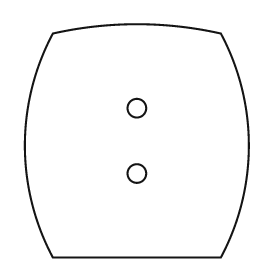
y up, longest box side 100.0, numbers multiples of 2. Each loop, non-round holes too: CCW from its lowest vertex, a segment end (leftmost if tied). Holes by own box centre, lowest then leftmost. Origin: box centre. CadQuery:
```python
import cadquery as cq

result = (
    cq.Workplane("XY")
    .moveTo(-36.0, -50.0)
    .lineTo(36.0, -50.0)
    .threePointArc((48.0, -2.0), (36.0, 46.0))
    .threePointArc((0.0, 50.0), (-36.0, 46.0))
    .threePointArc((-48.0, -2.0), (-36.0, -50.0))
    .close()
    .moveTo(0.0, -14.0)
    .circle(4.0)
    .moveTo(0.0, 14.0)
    .circle(4.0)
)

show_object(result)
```